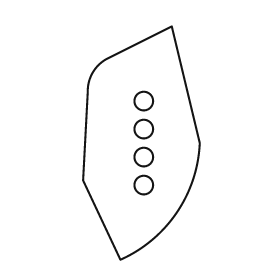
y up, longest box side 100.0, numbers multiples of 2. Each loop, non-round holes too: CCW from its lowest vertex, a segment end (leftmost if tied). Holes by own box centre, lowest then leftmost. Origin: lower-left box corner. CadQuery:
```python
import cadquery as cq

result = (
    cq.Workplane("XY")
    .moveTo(16.0, 0.0)
    .threePointArc((40.0, 20.0), (50.0, 50.0))
    .lineTo(38.0, 100.0)
    .lineTo(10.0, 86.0)
    .threePointArc((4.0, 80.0), (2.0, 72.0))
    .lineTo(0.0, 34.0)
    .close()
    .moveTo(26.0, 32.0)
    .circle(4.0)
    .moveTo(26.0, 44.0)
    .circle(4.0)
    .moveTo(26.0, 56.0)
    .circle(4.0)
    .moveTo(26.0, 68.0)
    .circle(4.0)
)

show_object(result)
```